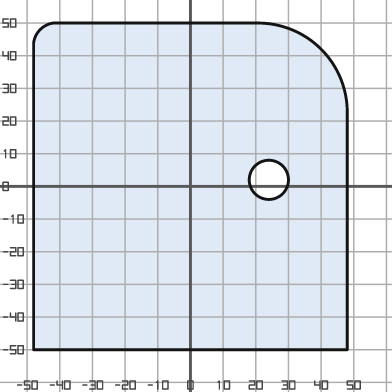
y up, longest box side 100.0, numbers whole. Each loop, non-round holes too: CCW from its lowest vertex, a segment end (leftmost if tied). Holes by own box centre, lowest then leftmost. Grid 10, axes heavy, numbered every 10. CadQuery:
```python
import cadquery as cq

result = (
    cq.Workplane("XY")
    .moveTo(-48.0, -50.0)
    .lineTo(48.0, -50.0)
    .lineTo(48.0, 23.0)
    .threePointArc((40.0, 42.0), (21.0, 50.0))
    .lineTo(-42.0, 50.0)
    .threePointArc((-46.0, 48.0), (-48.0, 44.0))
    .close()
    .moveTo(24.0, 2.0)
    .circle(6.0)
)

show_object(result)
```